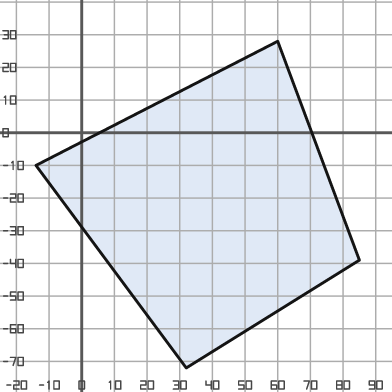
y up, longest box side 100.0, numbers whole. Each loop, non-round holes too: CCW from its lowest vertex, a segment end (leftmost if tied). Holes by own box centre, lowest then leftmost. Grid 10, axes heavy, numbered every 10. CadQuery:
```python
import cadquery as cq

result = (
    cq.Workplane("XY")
    .moveTo(32.0, -72.0)
    .lineTo(85.0, -39.0)
    .lineTo(60.0, 28.0)
    .lineTo(-14.0, -10.0)
    .close()
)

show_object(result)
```